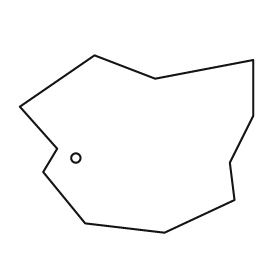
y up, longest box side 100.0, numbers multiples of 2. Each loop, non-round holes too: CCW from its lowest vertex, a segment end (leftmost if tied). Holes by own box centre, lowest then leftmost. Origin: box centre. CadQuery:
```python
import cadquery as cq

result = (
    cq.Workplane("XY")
    .moveTo(12.0, -38.0)
    .lineTo(42.0, -24.0)
    .lineTo(40.0, -8.0)
    .lineTo(50.0, 12.0)
    .lineTo(50.0, 36.0)
    .lineTo(8.0, 28.0)
    .lineTo(-18.0, 38.0)
    .lineTo(-50.0, 16.0)
    .lineTo(-34.0, -2.0)
    .lineTo(-40.0, -12.0)
    .lineTo(-22.0, -34.0)
    .close()
    .moveTo(-26.0, -6.0)
    .circle(2.0)
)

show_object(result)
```